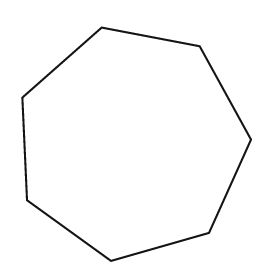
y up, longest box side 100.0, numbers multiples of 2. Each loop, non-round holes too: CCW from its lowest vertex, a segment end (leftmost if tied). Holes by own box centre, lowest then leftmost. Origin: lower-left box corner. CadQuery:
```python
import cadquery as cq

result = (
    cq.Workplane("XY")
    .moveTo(38.0, 0.0)
    .lineTo(80.0, 12.0)
    .lineTo(98.0, 52.0)
    .lineTo(76.0, 92.0)
    .lineTo(34.0, 100.0)
    .lineTo(0.0, 70.0)
    .lineTo(2.0, 26.0)
    .close()
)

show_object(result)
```